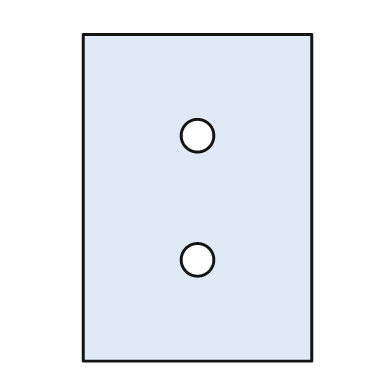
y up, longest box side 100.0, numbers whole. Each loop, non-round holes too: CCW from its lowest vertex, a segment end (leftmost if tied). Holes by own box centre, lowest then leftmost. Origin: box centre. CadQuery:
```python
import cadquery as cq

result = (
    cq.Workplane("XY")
    .moveTo(-35.0, -50.0)
    .lineTo(35.0, -50.0)
    .lineTo(35.0, 50.0)
    .lineTo(-35.0, 50.0)
    .close()
    .moveTo(0.0, -19.0)
    .circle(5.0)
    .moveTo(0.0, 19.0)
    .circle(5.0)
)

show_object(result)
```